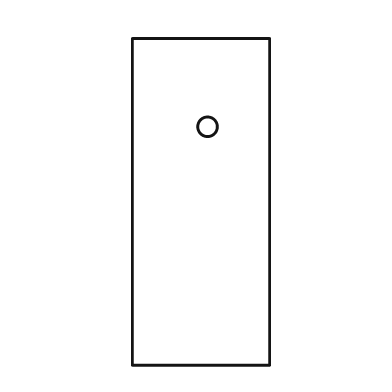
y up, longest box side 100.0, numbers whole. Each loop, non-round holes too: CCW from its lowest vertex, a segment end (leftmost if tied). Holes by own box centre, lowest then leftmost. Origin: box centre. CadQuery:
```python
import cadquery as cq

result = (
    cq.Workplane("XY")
    .moveTo(-21.0, -50.0)
    .lineTo(21.0, -50.0)
    .lineTo(21.0, 50.0)
    .lineTo(-21.0, 50.0)
    .close()
    .moveTo(2.0, 23.0)
    .circle(3.0)
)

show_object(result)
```